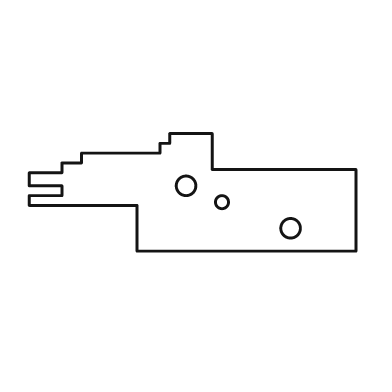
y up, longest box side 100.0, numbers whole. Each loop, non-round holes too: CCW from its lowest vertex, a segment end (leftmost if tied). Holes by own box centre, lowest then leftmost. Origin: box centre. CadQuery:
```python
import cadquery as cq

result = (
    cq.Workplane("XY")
    .moveTo(-17.0, -18.0)
    .lineTo(50.0, -18.0)
    .lineTo(50.0, 7.0)
    .lineTo(6.0, 7.0)
    .lineTo(6.0, 18.0)
    .lineTo(-7.0, 18.0)
    .lineTo(-7.0, 15.0)
    .lineTo(-10.0, 15.0)
    .lineTo(-10.0, 12.0)
    .lineTo(-34.0, 12.0)
    .lineTo(-34.0, 9.0)
    .lineTo(-40.0, 9.0)
    .lineTo(-40.0, 6.0)
    .lineTo(-50.0, 6.0)
    .lineTo(-50.0, 2.0)
    .lineTo(-40.0, 2.0)
    .lineTo(-40.0, -1.0)
    .lineTo(-50.0, -1.0)
    .lineTo(-50.0, -4.0)
    .lineTo(-17.0, -4.0)
    .close()
    .moveTo(30.0, -11.0)
    .circle(3.0)
    .moveTo(9.0, -3.0)
    .circle(2.0)
    .moveTo(-2.0, 2.0)
    .circle(3.0)
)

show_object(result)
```